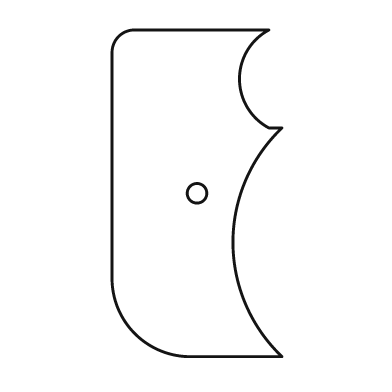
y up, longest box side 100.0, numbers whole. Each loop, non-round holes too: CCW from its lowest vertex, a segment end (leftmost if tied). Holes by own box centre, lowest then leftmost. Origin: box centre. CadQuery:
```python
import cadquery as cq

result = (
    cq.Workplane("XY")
    .moveTo(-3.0, -50.0)
    .lineTo(26.0, -50.0)
    .threePointArc((11.0, -15.0), (26.0, 20.0))
    .lineTo(22.0, 20.0)
    .threePointArc((13.0, 35.0), (22.0, 50.0))
    .lineTo(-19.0, 50.0)
    .threePointArc((-24.0, 48.0), (-26.0, 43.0))
    .lineTo(-26.0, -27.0)
    .threePointArc((-19.0, -43.0), (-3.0, -50.0))
    .close()
    .moveTo(0.0, 0.0)
    .circle(3.0)
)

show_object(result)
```